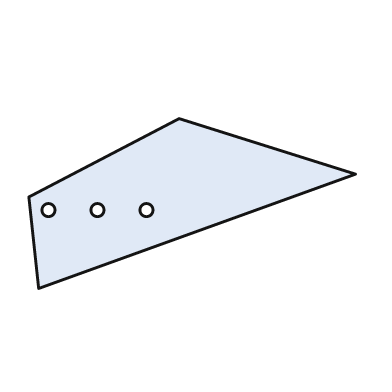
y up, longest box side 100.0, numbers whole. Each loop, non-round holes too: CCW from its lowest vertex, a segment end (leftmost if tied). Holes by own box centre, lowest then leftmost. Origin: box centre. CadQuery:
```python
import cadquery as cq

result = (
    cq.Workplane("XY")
    .moveTo(-47.0, -26.0)
    .lineTo(50.0, 9.0)
    .lineTo(-4.0, 26.0)
    .lineTo(-50.0, 2.0)
    .close()
    .moveTo(-44.0, -2.0)
    .circle(2.0)
    .moveTo(-29.0, -2.0)
    .circle(2.0)
    .moveTo(-14.0, -2.0)
    .circle(2.0)
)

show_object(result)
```